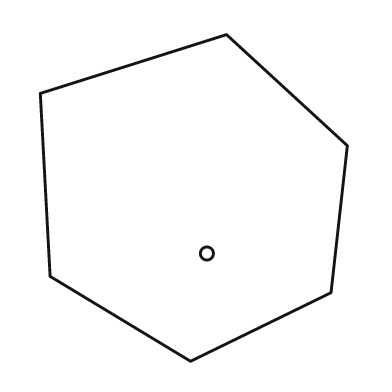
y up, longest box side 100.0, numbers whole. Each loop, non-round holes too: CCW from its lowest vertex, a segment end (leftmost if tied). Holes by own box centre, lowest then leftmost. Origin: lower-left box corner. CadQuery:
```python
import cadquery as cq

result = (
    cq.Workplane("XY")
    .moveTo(46.0, 0.0)
    .lineTo(89.0, 21.0)
    .lineTo(94.0, 66.0)
    .lineTo(57.0, 100.0)
    .lineTo(0.0, 82.0)
    .lineTo(3.0, 26.0)
    .close()
    .moveTo(51.0, 33.0)
    .circle(2.0)
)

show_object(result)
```